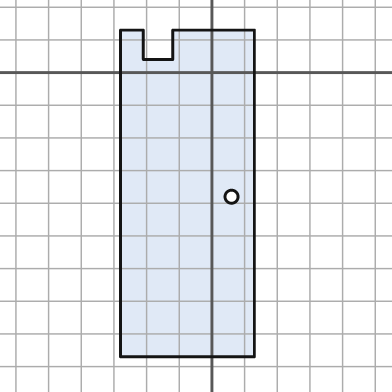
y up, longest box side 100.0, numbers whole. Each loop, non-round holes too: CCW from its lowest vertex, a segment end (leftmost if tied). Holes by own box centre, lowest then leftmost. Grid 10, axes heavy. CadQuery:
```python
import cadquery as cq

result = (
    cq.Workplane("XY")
    .moveTo(-28.0, -87.0)
    .lineTo(13.0, -87.0)
    .lineTo(13.0, 13.0)
    .lineTo(-12.0, 13.0)
    .lineTo(-12.0, 4.0)
    .lineTo(-21.0, 4.0)
    .lineTo(-21.0, 13.0)
    .lineTo(-28.0, 13.0)
    .close()
    .moveTo(6.0, -38.0)
    .circle(2.0)
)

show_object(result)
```